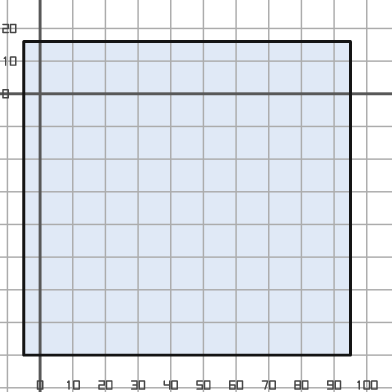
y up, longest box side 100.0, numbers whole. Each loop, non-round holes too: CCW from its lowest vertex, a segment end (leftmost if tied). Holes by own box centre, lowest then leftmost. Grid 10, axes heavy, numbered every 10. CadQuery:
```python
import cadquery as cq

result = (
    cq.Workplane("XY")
    .moveTo(-5.0, -80.0)
    .lineTo(95.0, -80.0)
    .lineTo(95.0, 16.0)
    .lineTo(-5.0, 16.0)
    .close()
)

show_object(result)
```